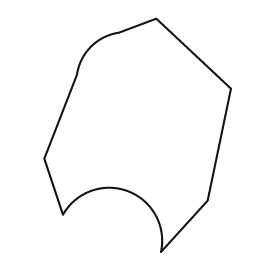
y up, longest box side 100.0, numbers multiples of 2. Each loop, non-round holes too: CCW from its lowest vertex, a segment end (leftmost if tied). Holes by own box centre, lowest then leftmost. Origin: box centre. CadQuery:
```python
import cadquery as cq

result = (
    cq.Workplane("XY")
    .moveTo(10.0, -50.0)
    .lineTo(30.0, -28.0)
    .lineTo(40.0, 20.0)
    .lineTo(8.0, 50.0)
    .lineTo(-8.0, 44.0)
    .threePointArc((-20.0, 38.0), (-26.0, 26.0))
    .lineTo(-40.0, -10.0)
    .lineTo(-32.0, -34.0)
    .threePointArc((-4.0, -24.0), (10.0, -50.0))
    .close()
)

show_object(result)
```